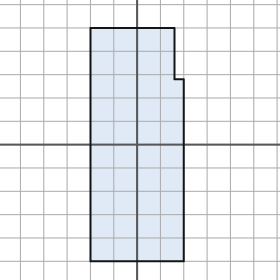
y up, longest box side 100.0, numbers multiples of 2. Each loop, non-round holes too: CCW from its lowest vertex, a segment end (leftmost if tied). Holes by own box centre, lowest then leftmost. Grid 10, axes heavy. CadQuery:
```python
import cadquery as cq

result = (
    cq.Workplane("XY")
    .moveTo(-20.0, -50.0)
    .lineTo(20.0, -50.0)
    .lineTo(20.0, 28.0)
    .lineTo(16.0, 28.0)
    .lineTo(16.0, 50.0)
    .lineTo(-20.0, 50.0)
    .close()
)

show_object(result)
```